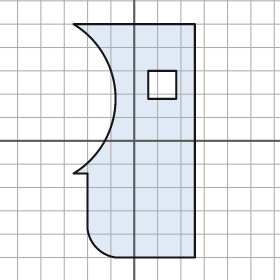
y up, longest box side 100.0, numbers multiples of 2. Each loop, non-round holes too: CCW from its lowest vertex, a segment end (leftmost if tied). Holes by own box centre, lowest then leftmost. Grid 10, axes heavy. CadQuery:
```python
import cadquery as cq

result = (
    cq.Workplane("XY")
    .moveTo(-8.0, -50.0)
    .lineTo(26.0, -50.0)
    .lineTo(26.0, 50.0)
    .lineTo(-26.0, 50.0)
    .threePointArc((-8.0, 18.0), (-26.0, -14.0))
    .lineTo(-20.0, -14.0)
    .lineTo(-20.0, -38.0)
    .threePointArc((-16.0, -46.0), (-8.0, -50.0))
    .close()
    .moveTo(6.0, 18.0)
    .lineTo(18.0, 18.0)
    .lineTo(18.0, 30.0)
    .lineTo(6.0, 30.0)
    .close()
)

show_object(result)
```